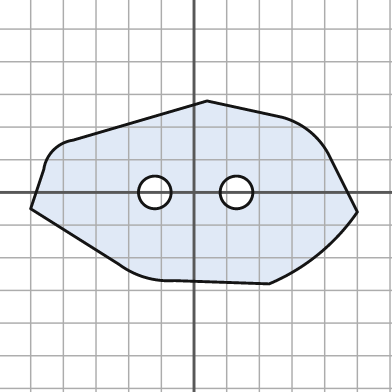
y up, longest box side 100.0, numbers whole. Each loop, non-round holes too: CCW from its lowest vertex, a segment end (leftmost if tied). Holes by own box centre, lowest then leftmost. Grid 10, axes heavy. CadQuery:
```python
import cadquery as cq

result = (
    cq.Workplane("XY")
    .moveTo(23.0, -28.0)
    .threePointArc((38.0, -19.0), (50.0, -6.0))
    .lineTo(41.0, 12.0)
    .threePointArc((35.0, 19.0), (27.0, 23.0))
    .lineTo(4.0, 28.0)
    .lineTo(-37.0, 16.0)
    .threePointArc((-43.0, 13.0), (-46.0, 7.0))
    .lineTo(-50.0, -5.0)
    .lineTo(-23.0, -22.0)
    .threePointArc((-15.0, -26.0), (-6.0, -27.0))
    .close()
    .moveTo(-12.0, 0.0)
    .circle(5.0)
    .moveTo(13.0, 0.0)
    .circle(5.0)
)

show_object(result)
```